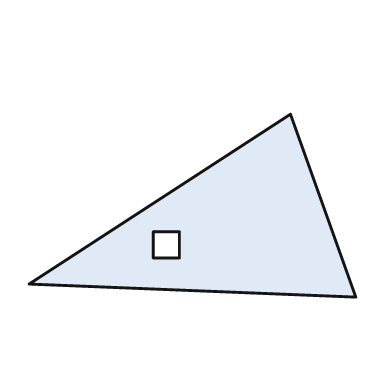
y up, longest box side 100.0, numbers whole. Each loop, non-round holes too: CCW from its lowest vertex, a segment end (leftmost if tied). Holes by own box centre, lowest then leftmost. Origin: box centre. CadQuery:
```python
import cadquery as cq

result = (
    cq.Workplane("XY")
    .moveTo(50.0, -28.0)
    .lineTo(30.0, 28.0)
    .lineTo(-50.0, -24.0)
    .close()
    .moveTo(-12.0, -16.0)
    .lineTo(-4.0, -16.0)
    .lineTo(-4.0, -8.0)
    .lineTo(-12.0, -8.0)
    .close()
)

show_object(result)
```